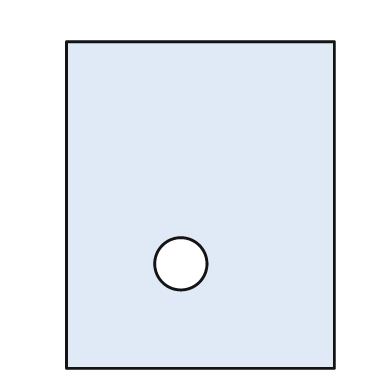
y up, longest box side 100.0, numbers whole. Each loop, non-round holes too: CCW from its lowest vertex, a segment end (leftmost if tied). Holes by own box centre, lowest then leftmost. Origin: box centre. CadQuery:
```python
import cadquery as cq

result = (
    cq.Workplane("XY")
    .moveTo(-41.0, -50.0)
    .lineTo(41.0, -50.0)
    .lineTo(41.0, 50.0)
    .lineTo(-41.0, 50.0)
    .close()
    .moveTo(-6.0, -18.0)
    .circle(8.0)
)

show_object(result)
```